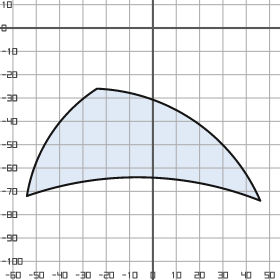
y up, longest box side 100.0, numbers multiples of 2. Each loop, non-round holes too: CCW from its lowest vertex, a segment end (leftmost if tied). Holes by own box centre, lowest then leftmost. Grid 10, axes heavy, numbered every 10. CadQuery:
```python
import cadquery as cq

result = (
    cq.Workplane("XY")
    .moveTo(46.0, -74.0)
    .threePointArc((18.0, -40.0), (-24.0, -26.0))
    .threePointArc((-44.0, -46.0), (-54.0, -72.0))
    .threePointArc((-4.0, -64.0), (46.0, -74.0))
    .close()
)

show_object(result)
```